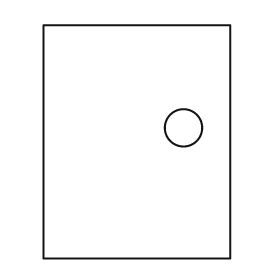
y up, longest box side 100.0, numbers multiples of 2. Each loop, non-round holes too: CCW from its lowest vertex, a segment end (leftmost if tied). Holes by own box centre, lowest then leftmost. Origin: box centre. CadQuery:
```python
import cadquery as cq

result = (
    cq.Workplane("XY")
    .moveTo(-40.0, -50.0)
    .lineTo(40.0, -50.0)
    .lineTo(40.0, 50.0)
    .lineTo(-40.0, 50.0)
    .close()
    .moveTo(20.0, 6.0)
    .circle(8.0)
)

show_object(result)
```